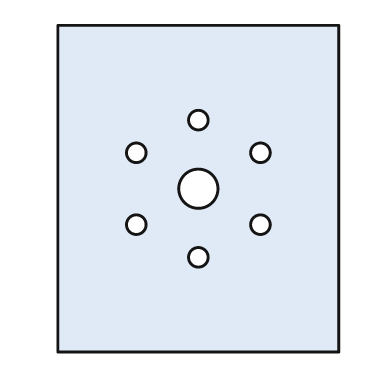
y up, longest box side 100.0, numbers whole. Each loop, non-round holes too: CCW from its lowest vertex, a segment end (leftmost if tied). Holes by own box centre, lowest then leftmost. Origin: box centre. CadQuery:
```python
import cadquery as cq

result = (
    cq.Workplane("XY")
    .moveTo(-43.0, -50.0)
    .lineTo(43.0, -50.0)
    .lineTo(43.0, 50.0)
    .lineTo(-43.0, 50.0)
    .close()
    .moveTo(0.0, -21.0)
    .circle(3.0)
    .moveTo(-19.0, -11.0)
    .circle(3.0)
    .moveTo(19.0, -11.0)
    .circle(3.0)
    .moveTo(0.0, 0.0)
    .circle(6.0)
    .moveTo(-19.0, 11.0)
    .circle(3.0)
    .moveTo(19.0, 11.0)
    .circle(3.0)
    .moveTo(0.0, 21.0)
    .circle(3.0)
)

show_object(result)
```